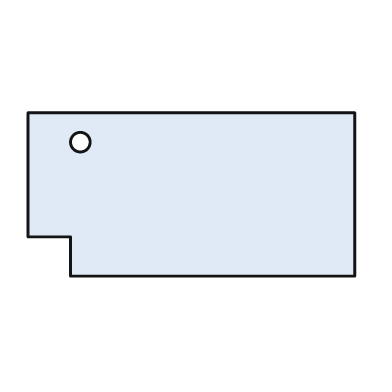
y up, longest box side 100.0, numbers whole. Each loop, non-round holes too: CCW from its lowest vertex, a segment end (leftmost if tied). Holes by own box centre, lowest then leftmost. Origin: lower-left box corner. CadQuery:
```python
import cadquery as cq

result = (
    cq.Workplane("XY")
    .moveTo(13.0, 0.0)
    .lineTo(100.0, 0.0)
    .lineTo(100.0, 50.0)
    .lineTo(0.0, 50.0)
    .lineTo(0.0, 12.0)
    .lineTo(13.0, 12.0)
    .close()
    .moveTo(16.0, 41.0)
    .circle(3.0)
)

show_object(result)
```